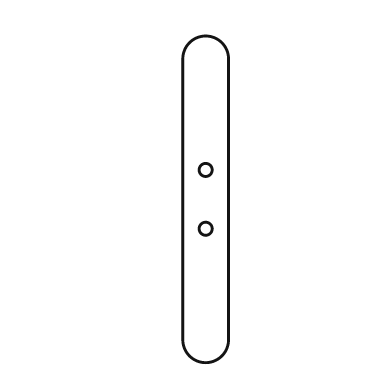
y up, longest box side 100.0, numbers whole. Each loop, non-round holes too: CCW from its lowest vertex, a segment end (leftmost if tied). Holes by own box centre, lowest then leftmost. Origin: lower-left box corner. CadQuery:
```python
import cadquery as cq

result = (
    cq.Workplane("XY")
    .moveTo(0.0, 7.0)
    .threePointArc((7.0, 0.0), (14.0, 7.0))
    .lineTo(14.0, 93.0)
    .threePointArc((7.0, 100.0), (0.0, 93.0))
    .close()
    .moveTo(7.0, 41.0)
    .circle(2.0)
    .moveTo(7.0, 59.0)
    .circle(2.0)
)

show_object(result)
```